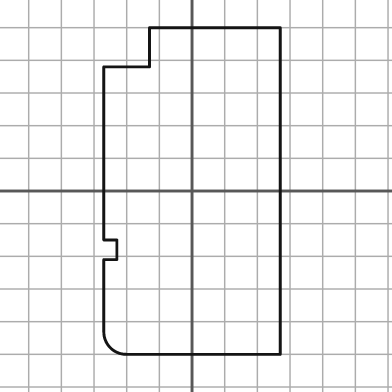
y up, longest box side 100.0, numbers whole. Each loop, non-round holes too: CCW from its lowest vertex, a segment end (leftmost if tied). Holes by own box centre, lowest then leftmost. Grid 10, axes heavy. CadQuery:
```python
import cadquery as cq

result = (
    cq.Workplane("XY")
    .moveTo(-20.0, -50.0)
    .lineTo(27.0, -50.0)
    .lineTo(27.0, 50.0)
    .lineTo(-13.0, 50.0)
    .lineTo(-13.0, 38.0)
    .lineTo(-27.0, 38.0)
    .lineTo(-27.0, -15.0)
    .lineTo(-23.0, -15.0)
    .lineTo(-23.0, -21.0)
    .lineTo(-27.0, -21.0)
    .lineTo(-27.0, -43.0)
    .threePointArc((-25.0, -48.0), (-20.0, -50.0))
    .close()
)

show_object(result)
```